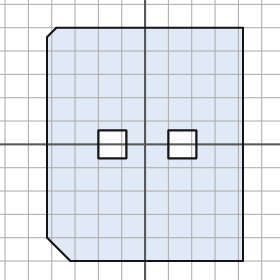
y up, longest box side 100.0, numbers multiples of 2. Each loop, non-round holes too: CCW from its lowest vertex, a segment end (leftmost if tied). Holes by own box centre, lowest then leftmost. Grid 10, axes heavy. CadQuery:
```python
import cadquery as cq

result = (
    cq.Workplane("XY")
    .moveTo(-32.0, -50.0)
    .lineTo(42.0, -50.0)
    .lineTo(42.0, 50.0)
    .lineTo(-38.0, 50.0)
    .lineTo(-42.0, 46.0)
    .lineTo(-42.0, -40.0)
    .close()
    .moveTo(-20.0, -6.0)
    .lineTo(-8.0, -6.0)
    .lineTo(-8.0, 6.0)
    .lineTo(-20.0, 6.0)
    .close()
    .moveTo(10.0, -6.0)
    .lineTo(22.0, -6.0)
    .lineTo(22.0, 6.0)
    .lineTo(10.0, 6.0)
    .close()
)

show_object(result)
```